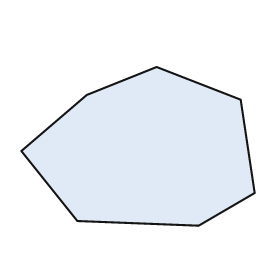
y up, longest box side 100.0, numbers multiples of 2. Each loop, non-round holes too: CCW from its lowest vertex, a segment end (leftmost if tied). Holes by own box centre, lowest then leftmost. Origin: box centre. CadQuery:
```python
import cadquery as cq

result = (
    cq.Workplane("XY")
    .moveTo(26.0, -34.0)
    .lineTo(50.0, -20.0)
    .lineTo(44.0, 20.0)
    .lineTo(8.0, 34.0)
    .lineTo(-22.0, 22.0)
    .lineTo(-50.0, -2.0)
    .lineTo(-26.0, -32.0)
    .close()
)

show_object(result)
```